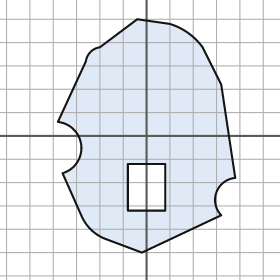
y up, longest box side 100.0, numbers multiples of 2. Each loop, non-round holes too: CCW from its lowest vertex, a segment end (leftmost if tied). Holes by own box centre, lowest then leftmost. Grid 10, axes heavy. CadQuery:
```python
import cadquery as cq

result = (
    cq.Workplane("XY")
    .moveTo(-2.0, -50.0)
    .lineTo(32.0, -34.0)
    .threePointArc((30.0, -24.0), (38.0, -18.0))
    .lineTo(32.0, 22.0)
    .lineTo(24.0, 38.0)
    .threePointArc((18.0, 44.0), (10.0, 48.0))
    .lineTo(-4.0, 50.0)
    .lineTo(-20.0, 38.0)
    .threePointArc((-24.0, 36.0), (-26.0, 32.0))
    .lineTo(-38.0, 6.0)
    .threePointArc((-28.0, -4.0), (-36.0, -16.0))
    .lineTo(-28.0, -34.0)
    .threePointArc((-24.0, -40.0), (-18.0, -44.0))
    .close()
    .moveTo(-8.0, -32.0)
    .lineTo(8.0, -32.0)
    .lineTo(8.0, -12.0)
    .lineTo(-8.0, -12.0)
    .close()
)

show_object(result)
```